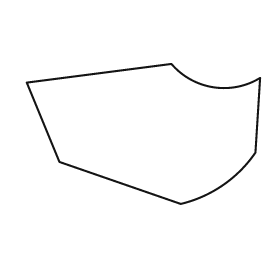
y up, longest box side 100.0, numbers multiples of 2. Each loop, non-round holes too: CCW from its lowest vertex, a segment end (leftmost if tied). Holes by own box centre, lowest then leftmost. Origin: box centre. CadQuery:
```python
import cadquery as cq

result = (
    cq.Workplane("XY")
    .moveTo(16.0, -30.0)
    .threePointArc((34.0, -22.0), (48.0, -8.0))
    .lineTo(50.0, 24.0)
    .threePointArc((30.0, 20.0), (12.0, 30.0))
    .lineTo(-50.0, 22.0)
    .lineTo(-36.0, -12.0)
    .close()
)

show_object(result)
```